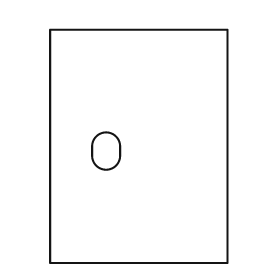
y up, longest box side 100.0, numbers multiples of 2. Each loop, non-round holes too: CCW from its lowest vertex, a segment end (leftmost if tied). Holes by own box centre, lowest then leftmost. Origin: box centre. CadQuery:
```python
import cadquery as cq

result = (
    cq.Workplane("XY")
    .moveTo(-38.0, -50.0)
    .lineTo(38.0, -50.0)
    .lineTo(38.0, 50.0)
    .lineTo(-38.0, 50.0)
    .close()
    .moveTo(-20.0, -4.0)
    .threePointArc((-14.0, -10.0), (-8.0, -4.0))
    .lineTo(-8.0, 0.0)
    .threePointArc((-14.0, 6.0), (-20.0, 0.0))
    .close()
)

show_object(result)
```